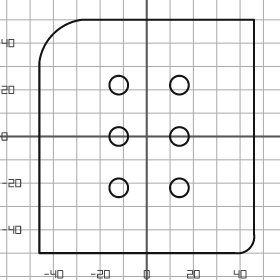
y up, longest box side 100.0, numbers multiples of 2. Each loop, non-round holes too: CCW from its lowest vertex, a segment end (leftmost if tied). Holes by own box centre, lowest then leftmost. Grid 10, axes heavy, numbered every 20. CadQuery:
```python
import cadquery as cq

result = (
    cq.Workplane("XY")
    .moveTo(-46.0, -50.0)
    .lineTo(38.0, -50.0)
    .threePointArc((44.0, -48.0), (46.0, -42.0))
    .lineTo(46.0, 50.0)
    .lineTo(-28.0, 50.0)
    .threePointArc((-40.0, 44.0), (-46.0, 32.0))
    .close()
    .moveTo(-12.0, -22.0)
    .circle(4.0)
    .moveTo(14.0, -22.0)
    .circle(4.0)
    .moveTo(-12.0, 0.0)
    .circle(4.0)
    .moveTo(14.0, 0.0)
    .circle(4.0)
    .moveTo(-12.0, 22.0)
    .circle(4.0)
    .moveTo(14.0, 22.0)
    .circle(4.0)
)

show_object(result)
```